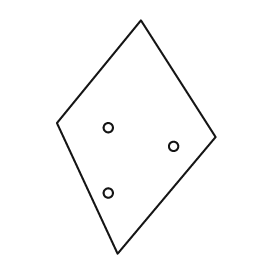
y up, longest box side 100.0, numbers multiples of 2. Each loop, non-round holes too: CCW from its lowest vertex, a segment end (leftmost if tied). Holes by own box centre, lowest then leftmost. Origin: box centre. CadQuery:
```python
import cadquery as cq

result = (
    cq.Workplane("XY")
    .moveTo(-8.0, -50.0)
    .lineTo(34.0, 0.0)
    .lineTo(2.0, 50.0)
    .lineTo(-34.0, 6.0)
    .close()
    .moveTo(-12.0, -24.0)
    .circle(2.0)
    .moveTo(16.0, -4.0)
    .circle(2.0)
    .moveTo(-12.0, 4.0)
    .circle(2.0)
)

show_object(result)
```